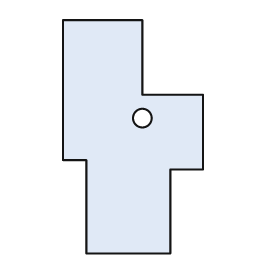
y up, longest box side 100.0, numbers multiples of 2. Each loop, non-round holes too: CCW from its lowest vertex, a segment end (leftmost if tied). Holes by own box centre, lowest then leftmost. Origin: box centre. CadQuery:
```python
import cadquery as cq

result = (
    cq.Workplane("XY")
    .moveTo(-20.0, -50.0)
    .lineTo(16.0, -50.0)
    .lineTo(16.0, -14.0)
    .lineTo(30.0, -14.0)
    .lineTo(30.0, 18.0)
    .lineTo(4.0, 18.0)
    .lineTo(4.0, 50.0)
    .lineTo(-30.0, 50.0)
    .lineTo(-30.0, -10.0)
    .lineTo(-20.0, -10.0)
    .close()
    .moveTo(4.0, 8.0)
    .circle(4.0)
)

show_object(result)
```